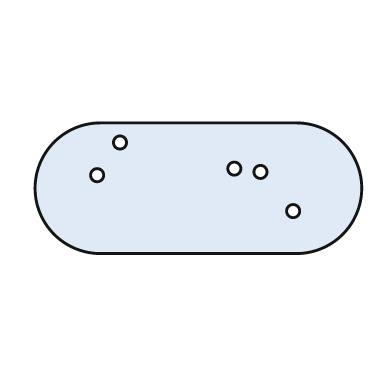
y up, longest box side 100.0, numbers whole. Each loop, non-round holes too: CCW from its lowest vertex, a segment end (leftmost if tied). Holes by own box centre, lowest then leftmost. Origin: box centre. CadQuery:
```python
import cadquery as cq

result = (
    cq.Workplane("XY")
    .moveTo(-30.0, -20.0)
    .lineTo(30.0, -20.0)
    .threePointArc((50.0, 0.0), (30.0, 20.0))
    .lineTo(-30.0, 20.0)
    .threePointArc((-50.0, 0.0), (-30.0, -20.0))
    .close()
    .moveTo(29.0, -7.0)
    .circle(2.0)
    .moveTo(-31.0, 4.0)
    .circle(2.0)
    .moveTo(19.0, 5.0)
    .circle(2.0)
    .moveTo(11.0, 6.0)
    .circle(2.0)
    .moveTo(-24.0, 14.0)
    .circle(2.0)
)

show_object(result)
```